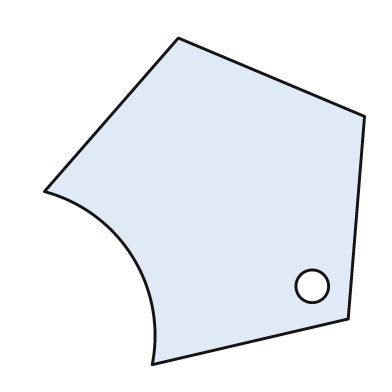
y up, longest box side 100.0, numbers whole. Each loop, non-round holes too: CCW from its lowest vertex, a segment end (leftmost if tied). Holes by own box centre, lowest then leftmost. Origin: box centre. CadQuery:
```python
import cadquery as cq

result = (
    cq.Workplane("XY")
    .moveTo(-16.0, -50.0)
    .lineTo(44.0, -36.0)
    .lineTo(49.0, 26.0)
    .lineTo(-8.0, 50.0)
    .lineTo(-49.0, 3.0)
    .threePointArc((-22.0, -17.0), (-16.0, -50.0))
    .close()
    .moveTo(33.0, -26.0)
    .circle(5.0)
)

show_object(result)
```